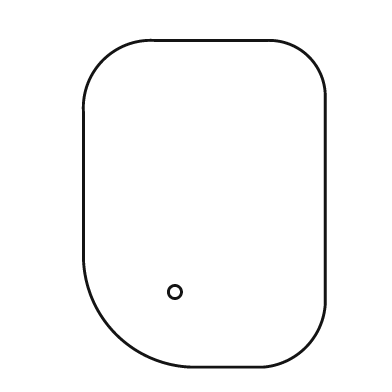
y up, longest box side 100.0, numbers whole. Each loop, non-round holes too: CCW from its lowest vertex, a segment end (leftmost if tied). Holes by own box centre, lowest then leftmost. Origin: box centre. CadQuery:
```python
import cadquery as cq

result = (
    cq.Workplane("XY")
    .moveTo(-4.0, -50.0)
    .lineTo(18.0, -50.0)
    .threePointArc((31.0, -44.0), (37.0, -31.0))
    .lineTo(37.0, 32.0)
    .threePointArc((32.0, 45.0), (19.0, 50.0))
    .lineTo(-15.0, 50.0)
    .threePointArc((-31.0, 44.0), (-37.0, 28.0))
    .lineTo(-37.0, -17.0)
    .threePointArc((-27.0, -40.0), (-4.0, -50.0))
    .close()
    .moveTo(-9.0, -27.0)
    .circle(2.0)
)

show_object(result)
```